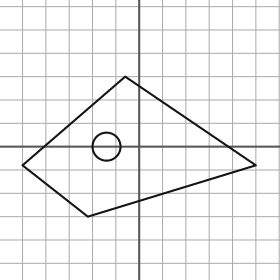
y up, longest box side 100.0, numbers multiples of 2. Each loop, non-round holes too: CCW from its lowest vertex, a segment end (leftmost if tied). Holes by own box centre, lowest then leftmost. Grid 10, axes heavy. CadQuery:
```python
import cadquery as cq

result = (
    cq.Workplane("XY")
    .moveTo(-22.0, -30.0)
    .lineTo(50.0, -8.0)
    .lineTo(-6.0, 30.0)
    .lineTo(-50.0, -8.0)
    .close()
    .moveTo(-14.0, 0.0)
    .circle(6.0)
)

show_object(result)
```